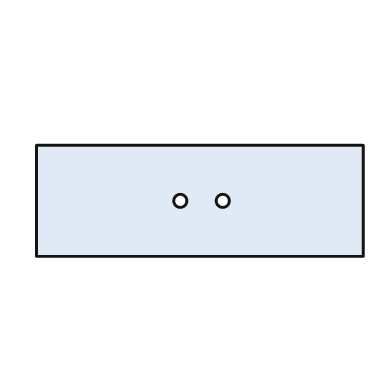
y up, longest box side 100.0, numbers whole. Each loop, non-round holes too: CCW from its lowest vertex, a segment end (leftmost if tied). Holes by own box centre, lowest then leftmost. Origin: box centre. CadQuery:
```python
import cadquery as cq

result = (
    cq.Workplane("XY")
    .moveTo(-50.0, -17.0)
    .lineTo(50.0, -17.0)
    .lineTo(50.0, 17.0)
    .lineTo(-50.0, 17.0)
    .close()
    .moveTo(-6.0, 0.0)
    .circle(2.0)
    .moveTo(7.0, 0.0)
    .circle(2.0)
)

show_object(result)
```